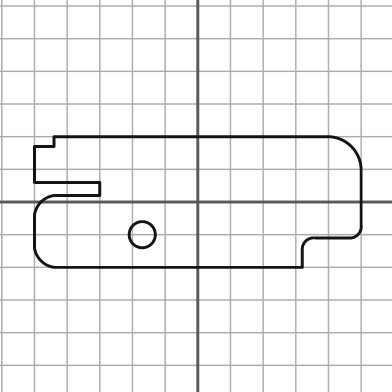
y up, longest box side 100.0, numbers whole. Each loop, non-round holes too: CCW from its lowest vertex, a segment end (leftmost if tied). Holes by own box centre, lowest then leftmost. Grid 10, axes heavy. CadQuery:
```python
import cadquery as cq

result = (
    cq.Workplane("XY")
    .moveTo(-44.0, -20.0)
    .lineTo(32.0, -20.0)
    .lineTo(32.0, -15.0)
    .threePointArc((33.0, -12.0), (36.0, -11.0))
    .lineTo(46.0, -11.0)
    .threePointArc((49.0, -10.0), (50.0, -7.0))
    .lineTo(50.0, 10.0)
    .threePointArc((47.0, 17.0), (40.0, 20.0))
    .lineTo(-44.0, 20.0)
    .lineTo(-44.0, 17.0)
    .lineTo(-50.0, 17.0)
    .lineTo(-50.0, 6.0)
    .lineTo(-30.0, 6.0)
    .lineTo(-30.0, 2.0)
    .lineTo(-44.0, 2.0)
    .threePointArc((-48.0, 0.0), (-50.0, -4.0))
    .lineTo(-50.0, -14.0)
    .threePointArc((-48.0, -18.0), (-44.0, -20.0))
    .close()
    .moveTo(-17.0, -10.0)
    .circle(4.0)
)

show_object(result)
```